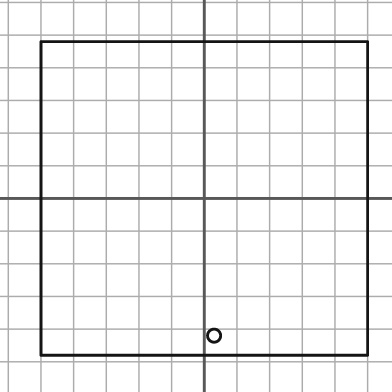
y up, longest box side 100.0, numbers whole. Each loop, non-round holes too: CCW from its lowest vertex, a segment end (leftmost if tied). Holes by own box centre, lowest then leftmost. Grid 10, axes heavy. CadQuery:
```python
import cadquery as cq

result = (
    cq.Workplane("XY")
    .moveTo(-50.0, -48.0)
    .lineTo(50.0, -48.0)
    .lineTo(50.0, 48.0)
    .lineTo(-50.0, 48.0)
    .close()
    .moveTo(3.0, -42.0)
    .circle(2.0)
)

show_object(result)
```